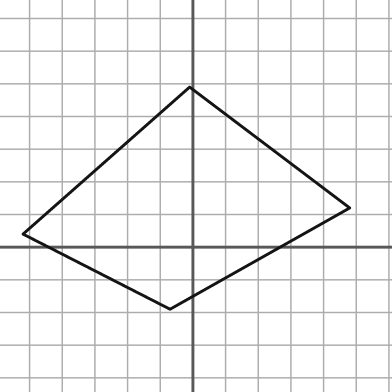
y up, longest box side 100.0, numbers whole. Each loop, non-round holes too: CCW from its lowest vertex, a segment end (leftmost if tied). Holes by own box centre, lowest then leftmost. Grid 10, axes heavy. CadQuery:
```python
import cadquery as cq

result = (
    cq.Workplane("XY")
    .moveTo(-7.0, -19.0)
    .lineTo(48.0, 12.0)
    .lineTo(-1.0, 49.0)
    .lineTo(-52.0, 4.0)
    .close()
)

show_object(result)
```